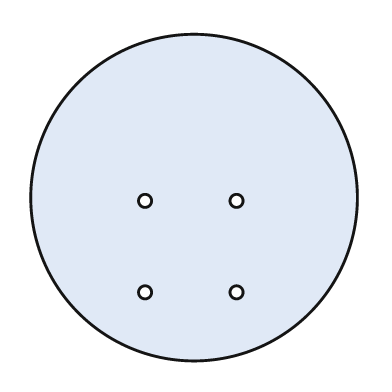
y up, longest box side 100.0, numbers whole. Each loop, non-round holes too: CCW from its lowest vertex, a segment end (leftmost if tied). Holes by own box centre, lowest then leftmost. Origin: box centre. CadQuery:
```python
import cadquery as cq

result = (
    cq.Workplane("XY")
    .moveTo(0.0, 0.0)
    .circle(50.0)
    .moveTo(-15.0, -29.0)
    .circle(2.0)
    .moveTo(13.0, -29.0)
    .circle(2.0)
    .moveTo(-15.0, -1.0)
    .circle(2.0)
    .moveTo(13.0, -1.0)
    .circle(2.0)
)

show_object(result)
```